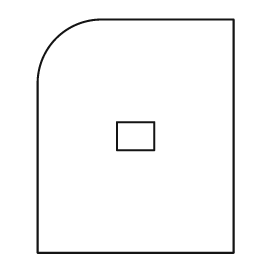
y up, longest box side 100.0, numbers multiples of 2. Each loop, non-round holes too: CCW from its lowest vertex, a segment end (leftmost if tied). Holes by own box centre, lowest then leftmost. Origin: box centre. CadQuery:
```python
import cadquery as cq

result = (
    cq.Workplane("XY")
    .moveTo(-42.0, -50.0)
    .lineTo(42.0, -50.0)
    .lineTo(42.0, 50.0)
    .lineTo(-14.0, 50.0)
    .threePointArc((-34.0, 42.0), (-42.0, 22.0))
    .close()
    .moveTo(-8.0, -6.0)
    .lineTo(8.0, -6.0)
    .lineTo(8.0, 6.0)
    .lineTo(-8.0, 6.0)
    .close()
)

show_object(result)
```